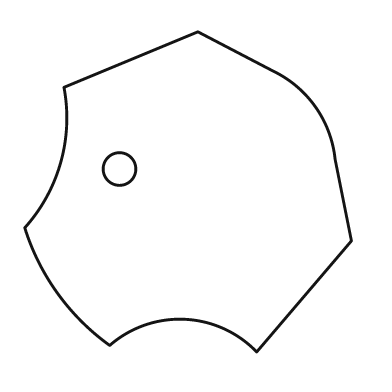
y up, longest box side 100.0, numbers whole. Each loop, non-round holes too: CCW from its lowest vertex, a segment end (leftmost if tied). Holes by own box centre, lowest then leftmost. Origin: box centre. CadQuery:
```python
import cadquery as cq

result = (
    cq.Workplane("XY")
    .moveTo(21.0, -49.0)
    .lineTo(50.0, -15.0)
    .lineTo(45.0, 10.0)
    .threePointArc((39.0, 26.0), (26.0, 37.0))
    .lineTo(3.0, 49.0)
    .lineTo(-38.0, 32.0)
    .threePointArc((-39.0, 9.0), (-50.0, -11.0))
    .threePointArc((-40.0, -31.0), (-24.0, -47.0))
    .threePointArc((-1.0, -39.0), (21.0, -49.0))
    .close()
    .moveTo(-21.0, 7.0)
    .circle(5.0)
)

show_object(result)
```